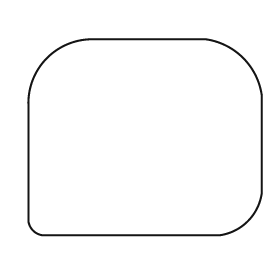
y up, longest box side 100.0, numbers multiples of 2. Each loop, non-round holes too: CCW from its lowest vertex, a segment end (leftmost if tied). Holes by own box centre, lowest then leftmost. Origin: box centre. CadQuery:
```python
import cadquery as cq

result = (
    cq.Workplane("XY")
    .moveTo(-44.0, -42.0)
    .lineTo(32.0, -42.0)
    .threePointArc((44.0, -36.0), (50.0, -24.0))
    .lineTo(50.0, 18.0)
    .threePointArc((42.0, 34.0), (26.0, 42.0))
    .lineTo(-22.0, 42.0)
    .threePointArc((-42.0, 34.0), (-50.0, 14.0))
    .lineTo(-50.0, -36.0)
    .threePointArc((-48.0, -40.0), (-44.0, -42.0))
    .close()
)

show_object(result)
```